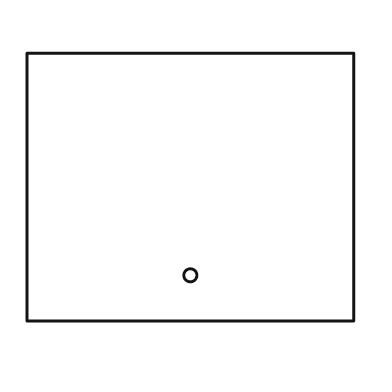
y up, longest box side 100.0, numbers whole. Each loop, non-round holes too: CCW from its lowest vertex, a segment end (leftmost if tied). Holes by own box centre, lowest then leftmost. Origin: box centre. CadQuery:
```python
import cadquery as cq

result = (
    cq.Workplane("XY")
    .moveTo(-50.0, -41.0)
    .lineTo(50.0, -41.0)
    .lineTo(50.0, 41.0)
    .lineTo(-50.0, 41.0)
    .close()
    .moveTo(0.0, -27.0)
    .circle(2.0)
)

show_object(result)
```